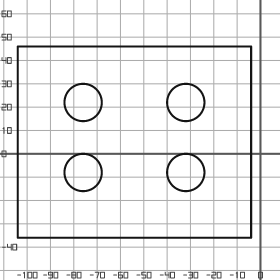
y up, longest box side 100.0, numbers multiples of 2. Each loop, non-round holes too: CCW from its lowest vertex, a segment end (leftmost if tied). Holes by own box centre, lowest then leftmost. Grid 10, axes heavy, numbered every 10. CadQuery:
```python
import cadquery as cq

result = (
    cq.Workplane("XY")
    .moveTo(-104.0, -36.0)
    .lineTo(-4.0, -36.0)
    .lineTo(-4.0, 46.0)
    .lineTo(-104.0, 46.0)
    .close()
    .moveTo(-76.0, -8.0)
    .circle(8.0)
    .moveTo(-32.0, -8.0)
    .circle(8.0)
    .moveTo(-76.0, 22.0)
    .circle(8.0)
    .moveTo(-32.0, 22.0)
    .circle(8.0)
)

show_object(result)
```